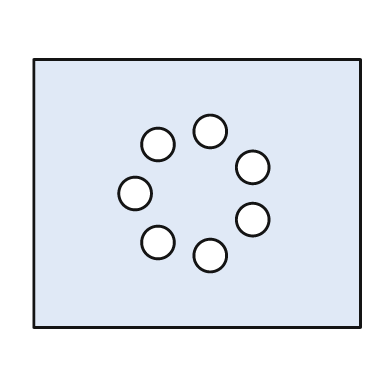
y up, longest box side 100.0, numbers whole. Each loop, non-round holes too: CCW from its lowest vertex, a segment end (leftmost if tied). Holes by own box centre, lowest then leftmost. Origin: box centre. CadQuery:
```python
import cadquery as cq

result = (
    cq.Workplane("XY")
    .moveTo(-50.0, -41.0)
    .lineTo(50.0, -41.0)
    .lineTo(50.0, 41.0)
    .lineTo(-50.0, 41.0)
    .close()
    .moveTo(4.0, -19.0)
    .circle(5.0)
    .moveTo(-12.0, -15.0)
    .circle(5.0)
    .moveTo(17.0, -8.0)
    .circle(5.0)
    .moveTo(-19.0, 0.0)
    .circle(5.0)
    .moveTo(17.0, 8.0)
    .circle(5.0)
    .moveTo(-12.0, 15.0)
    .circle(5.0)
    .moveTo(4.0, 19.0)
    .circle(5.0)
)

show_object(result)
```